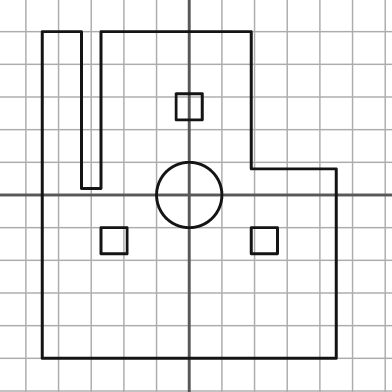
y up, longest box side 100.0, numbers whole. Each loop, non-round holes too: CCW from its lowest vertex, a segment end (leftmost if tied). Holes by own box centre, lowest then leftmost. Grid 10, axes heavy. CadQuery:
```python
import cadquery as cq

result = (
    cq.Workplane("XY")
    .moveTo(-45.0, -50.0)
    .lineTo(45.0, -50.0)
    .lineTo(45.0, 8.0)
    .lineTo(19.0, 8.0)
    .lineTo(19.0, 50.0)
    .lineTo(-27.0, 50.0)
    .lineTo(-27.0, 2.0)
    .lineTo(-33.0, 2.0)
    .lineTo(-33.0, 50.0)
    .lineTo(-45.0, 50.0)
    .close()
    .moveTo(-27.0, -18.0)
    .lineTo(-19.0, -18.0)
    .lineTo(-19.0, -10.0)
    .lineTo(-27.0, -10.0)
    .close()
    .moveTo(19.0, -18.0)
    .lineTo(27.0, -18.0)
    .lineTo(27.0, -10.0)
    .lineTo(19.0, -10.0)
    .close()
    .moveTo(0.0, 0.0)
    .circle(10.0)
    .moveTo(-4.0, 23.0)
    .lineTo(4.0, 23.0)
    .lineTo(4.0, 31.0)
    .lineTo(-4.0, 31.0)
    .close()
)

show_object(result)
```